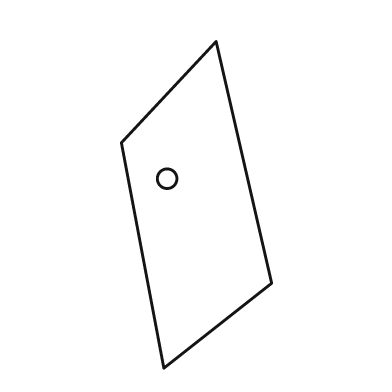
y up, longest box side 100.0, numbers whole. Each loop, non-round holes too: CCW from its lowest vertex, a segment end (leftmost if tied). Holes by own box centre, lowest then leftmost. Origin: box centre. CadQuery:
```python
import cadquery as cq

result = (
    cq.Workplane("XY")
    .moveTo(-10.0, -50.0)
    .lineTo(23.0, -24.0)
    .lineTo(6.0, 50.0)
    .lineTo(-23.0, 19.0)
    .close()
    .moveTo(-9.0, 8.0)
    .circle(3.0)
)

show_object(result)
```